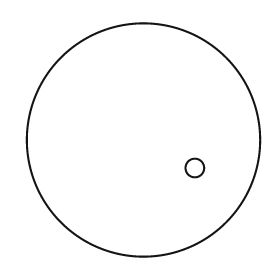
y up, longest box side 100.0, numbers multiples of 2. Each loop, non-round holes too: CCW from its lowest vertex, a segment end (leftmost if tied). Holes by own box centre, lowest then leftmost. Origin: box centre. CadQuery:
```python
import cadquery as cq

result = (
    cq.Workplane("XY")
    .moveTo(0.0, 0.0)
    .circle(50.0)
    .moveTo(22.0, -12.0)
    .circle(4.0)
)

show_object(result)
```